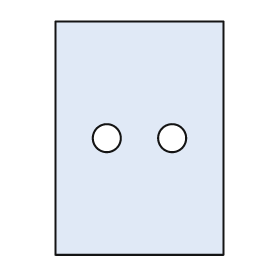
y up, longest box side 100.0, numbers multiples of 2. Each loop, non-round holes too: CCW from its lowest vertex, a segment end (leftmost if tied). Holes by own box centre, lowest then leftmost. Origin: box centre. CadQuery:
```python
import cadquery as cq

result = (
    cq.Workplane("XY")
    .moveTo(-36.0, -50.0)
    .lineTo(36.0, -50.0)
    .lineTo(36.0, 50.0)
    .lineTo(-36.0, 50.0)
    .close()
    .moveTo(-14.0, 0.0)
    .circle(6.0)
    .moveTo(14.0, 0.0)
    .circle(6.0)
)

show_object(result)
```